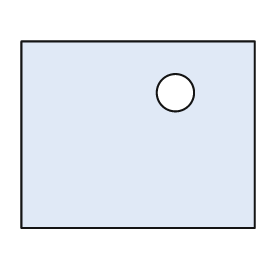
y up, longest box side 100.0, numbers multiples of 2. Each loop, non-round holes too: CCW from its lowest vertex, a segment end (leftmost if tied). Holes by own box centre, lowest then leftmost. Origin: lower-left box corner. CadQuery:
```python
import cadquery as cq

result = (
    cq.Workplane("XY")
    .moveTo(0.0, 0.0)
    .lineTo(100.0, 0.0)
    .lineTo(100.0, 80.0)
    .lineTo(0.0, 80.0)
    .close()
    .moveTo(66.0, 58.0)
    .circle(8.0)
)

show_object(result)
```